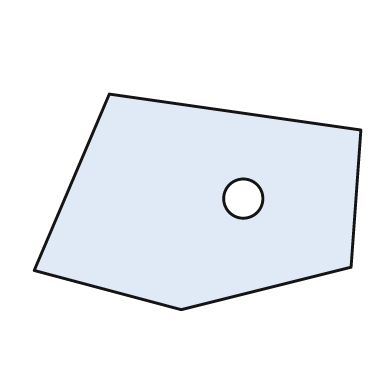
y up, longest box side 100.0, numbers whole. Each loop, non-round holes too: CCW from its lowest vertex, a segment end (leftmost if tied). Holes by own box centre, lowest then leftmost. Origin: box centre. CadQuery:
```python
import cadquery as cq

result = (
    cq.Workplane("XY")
    .moveTo(-5.0, -33.0)
    .lineTo(47.0, -20.0)
    .lineTo(50.0, 22.0)
    .lineTo(-27.0, 33.0)
    .lineTo(-50.0, -21.0)
    .close()
    .moveTo(14.0, 1.0)
    .circle(6.0)
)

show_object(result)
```